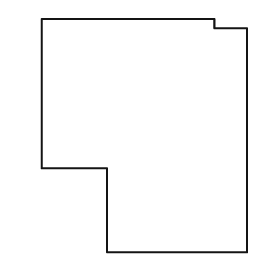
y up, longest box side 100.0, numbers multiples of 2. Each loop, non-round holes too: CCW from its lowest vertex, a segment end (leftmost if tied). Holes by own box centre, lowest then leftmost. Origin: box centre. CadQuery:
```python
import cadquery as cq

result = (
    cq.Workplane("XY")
    .moveTo(-16.0, -50.0)
    .lineTo(44.0, -50.0)
    .lineTo(44.0, 46.0)
    .lineTo(30.0, 46.0)
    .lineTo(30.0, 50.0)
    .lineTo(-44.0, 50.0)
    .lineTo(-44.0, -14.0)
    .lineTo(-16.0, -14.0)
    .close()
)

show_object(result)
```